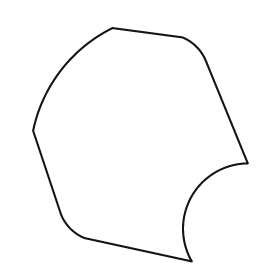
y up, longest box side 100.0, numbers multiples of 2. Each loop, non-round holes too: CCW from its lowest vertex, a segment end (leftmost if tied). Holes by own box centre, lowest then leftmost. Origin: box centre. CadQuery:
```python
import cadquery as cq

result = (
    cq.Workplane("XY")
    .moveTo(22.0, -50.0)
    .threePointArc((22.0, -22.0), (46.0, -8.0))
    .lineTo(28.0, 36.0)
    .threePointArc((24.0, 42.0), (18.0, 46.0))
    .lineTo(-12.0, 50.0)
    .threePointArc((-34.0, 32.0), (-46.0, 6.0))
    .lineTo(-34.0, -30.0)
    .threePointArc((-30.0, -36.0), (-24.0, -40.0))
    .close()
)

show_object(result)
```